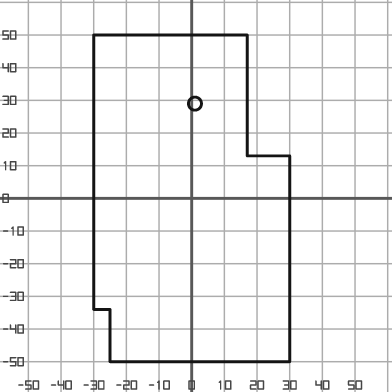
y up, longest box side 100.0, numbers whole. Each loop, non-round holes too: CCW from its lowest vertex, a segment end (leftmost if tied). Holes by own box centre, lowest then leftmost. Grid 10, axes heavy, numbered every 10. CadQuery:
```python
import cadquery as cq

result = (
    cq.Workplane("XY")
    .moveTo(-25.0, -50.0)
    .lineTo(30.0, -50.0)
    .lineTo(30.0, 13.0)
    .lineTo(17.0, 13.0)
    .lineTo(17.0, 50.0)
    .lineTo(-30.0, 50.0)
    .lineTo(-30.0, -34.0)
    .lineTo(-25.0, -34.0)
    .close()
    .moveTo(1.0, 29.0)
    .circle(2.0)
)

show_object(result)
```